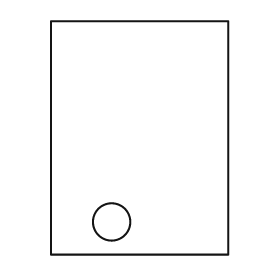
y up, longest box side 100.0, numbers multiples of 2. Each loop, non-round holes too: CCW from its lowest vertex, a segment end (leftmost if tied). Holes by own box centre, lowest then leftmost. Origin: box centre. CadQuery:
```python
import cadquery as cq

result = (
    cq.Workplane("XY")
    .moveTo(-38.0, -50.0)
    .lineTo(38.0, -50.0)
    .lineTo(38.0, 50.0)
    .lineTo(-38.0, 50.0)
    .close()
    .moveTo(-12.0, -36.0)
    .circle(8.0)
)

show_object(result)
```